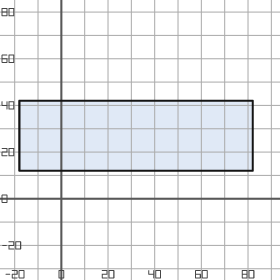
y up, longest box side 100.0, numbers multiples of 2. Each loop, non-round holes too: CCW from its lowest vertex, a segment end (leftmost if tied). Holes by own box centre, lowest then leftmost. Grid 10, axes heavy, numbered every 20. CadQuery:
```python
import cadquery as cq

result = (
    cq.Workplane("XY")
    .moveTo(-18.0, 12.0)
    .lineTo(82.0, 12.0)
    .lineTo(82.0, 42.0)
    .lineTo(-18.0, 42.0)
    .close()
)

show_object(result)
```